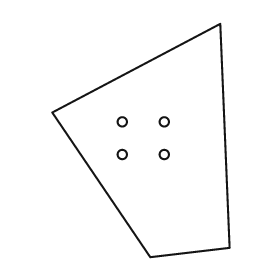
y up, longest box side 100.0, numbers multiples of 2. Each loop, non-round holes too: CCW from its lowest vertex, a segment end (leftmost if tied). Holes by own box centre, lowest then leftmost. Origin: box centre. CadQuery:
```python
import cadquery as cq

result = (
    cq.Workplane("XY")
    .moveTo(4.0, -50.0)
    .lineTo(38.0, -46.0)
    .lineTo(34.0, 50.0)
    .lineTo(-38.0, 12.0)
    .close()
    .moveTo(-8.0, -6.0)
    .circle(2.0)
    .moveTo(10.0, -6.0)
    .circle(2.0)
    .moveTo(-8.0, 8.0)
    .circle(2.0)
    .moveTo(10.0, 8.0)
    .circle(2.0)
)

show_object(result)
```